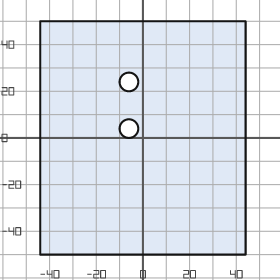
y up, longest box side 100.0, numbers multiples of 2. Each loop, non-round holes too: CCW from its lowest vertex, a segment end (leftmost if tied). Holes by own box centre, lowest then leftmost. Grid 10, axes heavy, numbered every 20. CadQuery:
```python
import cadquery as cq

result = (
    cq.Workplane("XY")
    .moveTo(-44.0, -50.0)
    .lineTo(44.0, -50.0)
    .lineTo(44.0, 50.0)
    .lineTo(-44.0, 50.0)
    .close()
    .moveTo(-6.0, 4.0)
    .circle(4.0)
    .moveTo(-6.0, 24.0)
    .circle(4.0)
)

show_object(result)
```